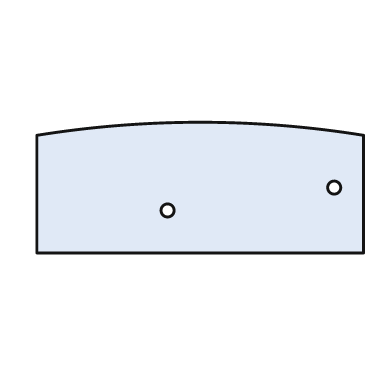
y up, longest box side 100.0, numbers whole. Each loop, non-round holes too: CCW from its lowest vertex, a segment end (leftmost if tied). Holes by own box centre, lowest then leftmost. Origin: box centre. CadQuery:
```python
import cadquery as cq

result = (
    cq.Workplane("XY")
    .moveTo(-50.0, -20.0)
    .lineTo(50.0, -20.0)
    .lineTo(50.0, 16.0)
    .threePointArc((0.0, 20.0), (-50.0, 16.0))
    .close()
    .moveTo(-10.0, -7.0)
    .circle(2.0)
    .moveTo(41.0, 0.0)
    .circle(2.0)
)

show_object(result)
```